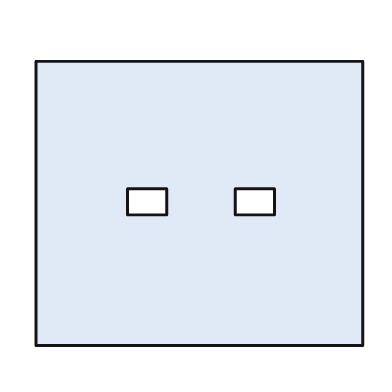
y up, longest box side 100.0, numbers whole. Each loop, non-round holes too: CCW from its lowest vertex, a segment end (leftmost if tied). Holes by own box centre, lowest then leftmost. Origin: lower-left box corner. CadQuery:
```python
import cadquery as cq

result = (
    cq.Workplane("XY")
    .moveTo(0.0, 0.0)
    .lineTo(100.0, 0.0)
    .lineTo(100.0, 87.0)
    .lineTo(0.0, 87.0)
    .close()
    .moveTo(28.0, 40.0)
    .lineTo(40.0, 40.0)
    .lineTo(40.0, 48.0)
    .lineTo(28.0, 48.0)
    .close()
    .moveTo(61.0, 40.0)
    .lineTo(73.0, 40.0)
    .lineTo(73.0, 48.0)
    .lineTo(61.0, 48.0)
    .close()
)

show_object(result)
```